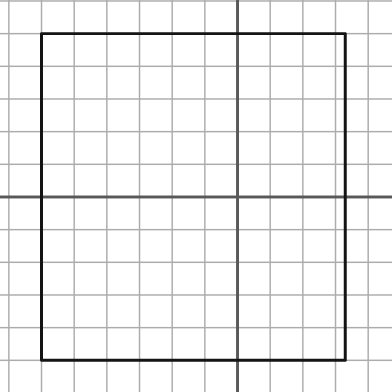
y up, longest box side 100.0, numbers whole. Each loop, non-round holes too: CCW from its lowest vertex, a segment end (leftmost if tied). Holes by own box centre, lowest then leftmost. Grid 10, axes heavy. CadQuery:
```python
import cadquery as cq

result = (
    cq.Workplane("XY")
    .moveTo(-60.0, -50.0)
    .lineTo(33.0, -50.0)
    .lineTo(33.0, 50.0)
    .lineTo(-60.0, 50.0)
    .close()
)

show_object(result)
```